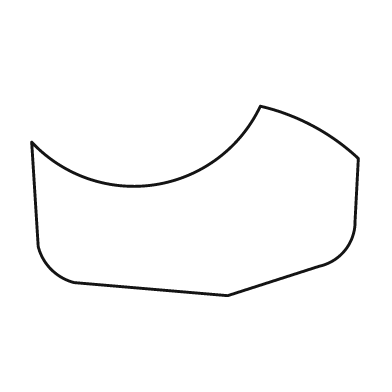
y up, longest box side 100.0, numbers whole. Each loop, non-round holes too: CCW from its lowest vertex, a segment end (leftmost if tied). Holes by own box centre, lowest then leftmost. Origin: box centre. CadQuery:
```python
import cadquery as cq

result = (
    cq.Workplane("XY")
    .moveTo(10.0, -29.0)
    .lineTo(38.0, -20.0)
    .threePointArc((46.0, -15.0), (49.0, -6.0))
    .lineTo(50.0, 13.0)
    .threePointArc((36.0, 23.0), (20.0, 29.0))
    .threePointArc((-12.0, 5.0), (-50.0, 18.0))
    .lineTo(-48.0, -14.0)
    .threePointArc((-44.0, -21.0), (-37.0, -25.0))
    .close()
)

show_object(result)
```